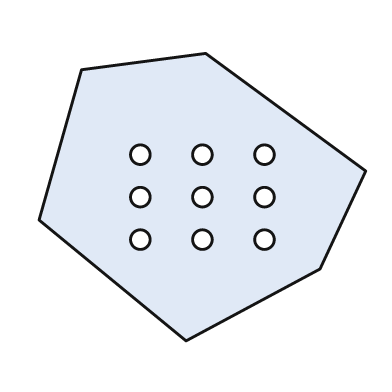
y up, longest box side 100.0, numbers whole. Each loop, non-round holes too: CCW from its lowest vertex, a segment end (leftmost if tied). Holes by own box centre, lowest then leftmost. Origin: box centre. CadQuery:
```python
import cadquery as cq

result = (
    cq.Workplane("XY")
    .moveTo(-5.0, -44.0)
    .lineTo(36.0, -22.0)
    .lineTo(50.0, 8.0)
    .lineTo(1.0, 44.0)
    .lineTo(-37.0, 39.0)
    .lineTo(-50.0, -7.0)
    .close()
    .moveTo(-19.0, -13.0)
    .circle(3.0)
    .moveTo(0.0, -13.0)
    .circle(3.0)
    .moveTo(19.0, -13.0)
    .circle(3.0)
    .moveTo(-19.0, 0.0)
    .circle(3.0)
    .moveTo(0.0, 0.0)
    .circle(3.0)
    .moveTo(19.0, 0.0)
    .circle(3.0)
    .moveTo(-19.0, 13.0)
    .circle(3.0)
    .moveTo(0.0, 13.0)
    .circle(3.0)
    .moveTo(19.0, 13.0)
    .circle(3.0)
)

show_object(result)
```